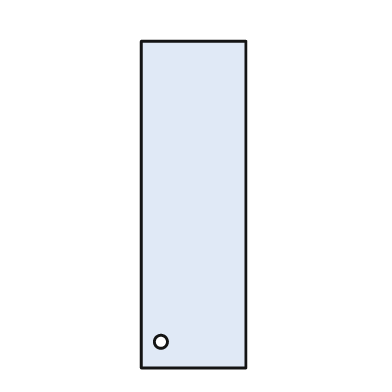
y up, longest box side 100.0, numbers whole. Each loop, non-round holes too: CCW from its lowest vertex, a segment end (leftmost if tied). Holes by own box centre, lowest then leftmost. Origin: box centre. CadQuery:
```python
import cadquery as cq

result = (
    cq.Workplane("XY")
    .moveTo(-16.0, -50.0)
    .lineTo(16.0, -50.0)
    .lineTo(16.0, 50.0)
    .lineTo(-16.0, 50.0)
    .close()
    .moveTo(-10.0, -42.0)
    .circle(2.0)
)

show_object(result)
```